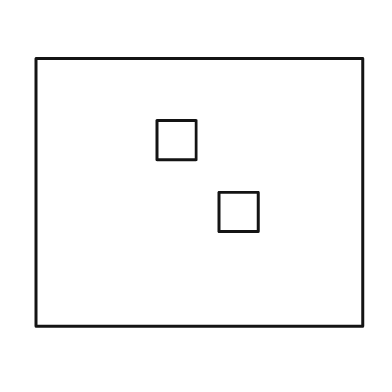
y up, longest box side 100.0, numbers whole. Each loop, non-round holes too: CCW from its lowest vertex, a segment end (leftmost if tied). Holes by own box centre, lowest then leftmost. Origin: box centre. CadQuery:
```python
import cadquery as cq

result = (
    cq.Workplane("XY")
    .moveTo(-50.0, -41.0)
    .lineTo(50.0, -41.0)
    .lineTo(50.0, 41.0)
    .lineTo(-50.0, 41.0)
    .close()
    .moveTo(6.0, -12.0)
    .lineTo(18.0, -12.0)
    .lineTo(18.0, 0.0)
    .lineTo(6.0, 0.0)
    .close()
    .moveTo(-13.0, 10.0)
    .lineTo(-1.0, 10.0)
    .lineTo(-1.0, 22.0)
    .lineTo(-13.0, 22.0)
    .close()
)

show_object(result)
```